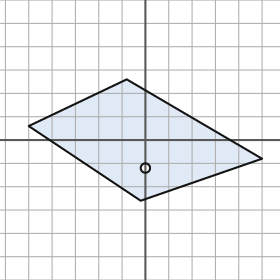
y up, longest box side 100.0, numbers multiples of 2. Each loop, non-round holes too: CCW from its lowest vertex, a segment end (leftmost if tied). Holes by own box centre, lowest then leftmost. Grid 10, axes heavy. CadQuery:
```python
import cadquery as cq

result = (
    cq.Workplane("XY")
    .moveTo(-2.0, -26.0)
    .lineTo(50.0, -8.0)
    .lineTo(-8.0, 26.0)
    .lineTo(-50.0, 6.0)
    .close()
    .moveTo(0.0, -12.0)
    .circle(2.0)
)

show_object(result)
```